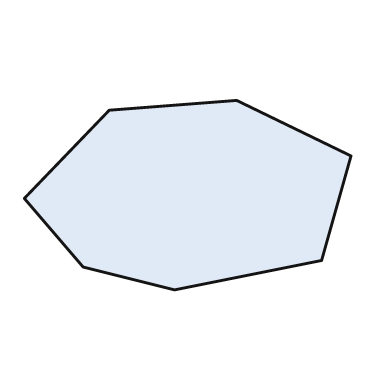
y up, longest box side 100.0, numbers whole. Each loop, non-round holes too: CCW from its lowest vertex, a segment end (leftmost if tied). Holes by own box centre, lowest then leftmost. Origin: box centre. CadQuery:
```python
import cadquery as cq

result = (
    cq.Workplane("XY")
    .moveTo(-4.0, -29.0)
    .lineTo(41.0, -20.0)
    .lineTo(50.0, 12.0)
    .lineTo(15.0, 29.0)
    .lineTo(-24.0, 26.0)
    .lineTo(-50.0, -1.0)
    .lineTo(-32.0, -22.0)
    .close()
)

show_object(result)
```